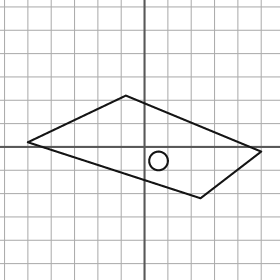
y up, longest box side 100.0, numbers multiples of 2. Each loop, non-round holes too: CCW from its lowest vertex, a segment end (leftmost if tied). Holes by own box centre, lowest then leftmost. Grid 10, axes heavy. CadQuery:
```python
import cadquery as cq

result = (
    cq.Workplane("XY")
    .moveTo(24.0, -22.0)
    .lineTo(50.0, -2.0)
    .lineTo(-8.0, 22.0)
    .lineTo(-50.0, 2.0)
    .close()
    .moveTo(6.0, -6.0)
    .circle(4.0)
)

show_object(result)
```